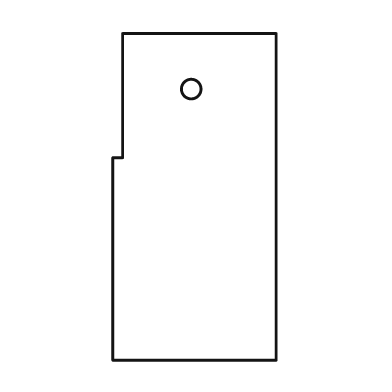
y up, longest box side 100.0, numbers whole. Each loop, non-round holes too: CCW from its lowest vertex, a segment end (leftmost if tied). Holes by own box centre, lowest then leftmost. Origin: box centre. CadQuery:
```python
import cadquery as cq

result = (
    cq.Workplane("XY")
    .moveTo(-25.0, -50.0)
    .lineTo(25.0, -50.0)
    .lineTo(25.0, 50.0)
    .lineTo(-22.0, 50.0)
    .lineTo(-22.0, 12.0)
    .lineTo(-25.0, 12.0)
    .close()
    .moveTo(-1.0, 33.0)
    .circle(3.0)
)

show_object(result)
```